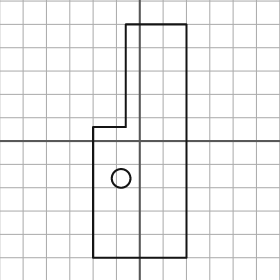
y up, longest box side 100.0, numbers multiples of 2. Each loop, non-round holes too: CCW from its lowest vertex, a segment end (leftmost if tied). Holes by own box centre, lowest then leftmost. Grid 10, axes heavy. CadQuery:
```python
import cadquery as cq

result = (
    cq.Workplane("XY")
    .moveTo(-20.0, -50.0)
    .lineTo(20.0, -50.0)
    .lineTo(20.0, 50.0)
    .lineTo(-6.0, 50.0)
    .lineTo(-6.0, 6.0)
    .lineTo(-20.0, 6.0)
    .close()
    .moveTo(-8.0, -16.0)
    .circle(4.0)
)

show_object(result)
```